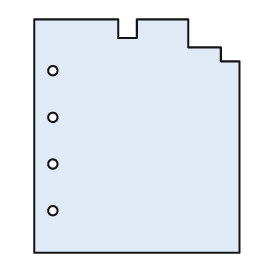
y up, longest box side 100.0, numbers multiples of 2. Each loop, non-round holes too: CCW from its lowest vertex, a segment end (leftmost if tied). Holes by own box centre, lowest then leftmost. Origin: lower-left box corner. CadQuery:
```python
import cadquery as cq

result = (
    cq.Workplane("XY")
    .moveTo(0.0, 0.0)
    .lineTo(88.0, 0.0)
    .lineTo(88.0, 82.0)
    .lineTo(80.0, 82.0)
    .lineTo(80.0, 88.0)
    .lineTo(66.0, 88.0)
    .lineTo(66.0, 100.0)
    .lineTo(44.0, 100.0)
    .lineTo(44.0, 92.0)
    .lineTo(36.0, 92.0)
    .lineTo(36.0, 100.0)
    .lineTo(0.0, 100.0)
    .close()
    .moveTo(8.0, 18.0)
    .circle(2.0)
    .moveTo(8.0, 38.0)
    .circle(2.0)
    .moveTo(8.0, 58.0)
    .circle(2.0)
    .moveTo(8.0, 78.0)
    .circle(2.0)
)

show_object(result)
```